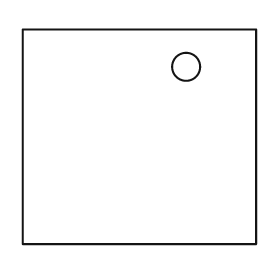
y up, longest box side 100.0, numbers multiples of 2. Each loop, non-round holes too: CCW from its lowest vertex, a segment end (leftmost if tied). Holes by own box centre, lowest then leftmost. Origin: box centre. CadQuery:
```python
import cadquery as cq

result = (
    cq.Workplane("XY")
    .moveTo(-50.0, -46.0)
    .lineTo(50.0, -46.0)
    .lineTo(50.0, 46.0)
    .lineTo(-50.0, 46.0)
    .close()
    .moveTo(20.0, 30.0)
    .circle(6.0)
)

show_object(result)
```